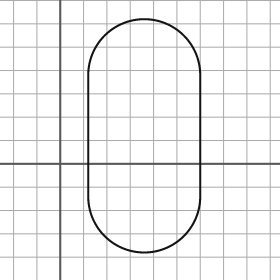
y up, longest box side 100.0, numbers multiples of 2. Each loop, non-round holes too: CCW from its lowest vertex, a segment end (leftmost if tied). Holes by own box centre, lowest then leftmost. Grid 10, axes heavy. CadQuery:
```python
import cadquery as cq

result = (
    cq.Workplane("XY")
    .moveTo(12.0, -14.0)
    .threePointArc((36.0, -38.0), (60.0, -14.0))
    .lineTo(60.0, 38.0)
    .threePointArc((36.0, 62.0), (12.0, 38.0))
    .close()
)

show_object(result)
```